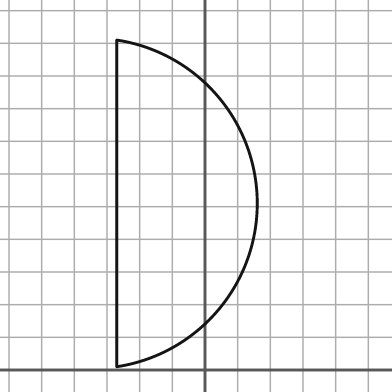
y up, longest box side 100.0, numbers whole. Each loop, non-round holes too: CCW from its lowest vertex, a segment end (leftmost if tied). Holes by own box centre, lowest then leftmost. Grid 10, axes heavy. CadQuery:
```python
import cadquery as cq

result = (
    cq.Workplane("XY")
    .moveTo(-27.0, 1.0)
    .threePointArc((16.0, 51.0), (-27.0, 101.0))
    .close()
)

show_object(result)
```